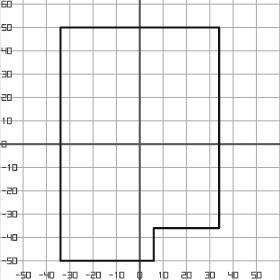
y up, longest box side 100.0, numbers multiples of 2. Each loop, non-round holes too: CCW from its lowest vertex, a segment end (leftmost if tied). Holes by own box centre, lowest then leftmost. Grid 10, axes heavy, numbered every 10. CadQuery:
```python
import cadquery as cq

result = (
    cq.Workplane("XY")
    .moveTo(-34.0, -50.0)
    .lineTo(6.0, -50.0)
    .lineTo(6.0, -36.0)
    .lineTo(34.0, -36.0)
    .lineTo(34.0, 50.0)
    .lineTo(-34.0, 50.0)
    .close()
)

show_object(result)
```